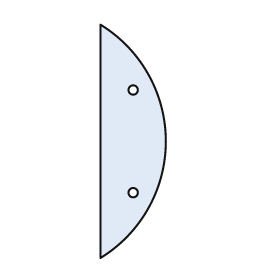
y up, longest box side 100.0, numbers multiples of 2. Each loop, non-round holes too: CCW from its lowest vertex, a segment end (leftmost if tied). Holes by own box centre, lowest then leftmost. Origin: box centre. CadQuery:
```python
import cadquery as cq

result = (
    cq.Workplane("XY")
    .moveTo(-14.0, -50.0)
    .threePointArc((14.0, 0.0), (-14.0, 50.0))
    .close()
    .moveTo(0.0, -22.0)
    .circle(2.0)
    .moveTo(0.0, 22.0)
    .circle(2.0)
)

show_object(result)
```